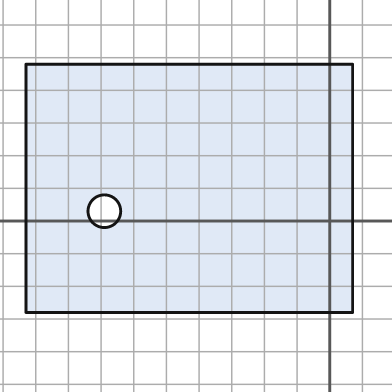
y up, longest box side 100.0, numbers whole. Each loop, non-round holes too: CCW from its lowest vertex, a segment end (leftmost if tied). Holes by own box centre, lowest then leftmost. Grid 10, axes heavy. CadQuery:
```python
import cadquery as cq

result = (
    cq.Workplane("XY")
    .moveTo(-93.0, -28.0)
    .lineTo(7.0, -28.0)
    .lineTo(7.0, 48.0)
    .lineTo(-93.0, 48.0)
    .close()
    .moveTo(-69.0, 3.0)
    .circle(5.0)
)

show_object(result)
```